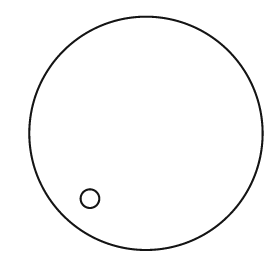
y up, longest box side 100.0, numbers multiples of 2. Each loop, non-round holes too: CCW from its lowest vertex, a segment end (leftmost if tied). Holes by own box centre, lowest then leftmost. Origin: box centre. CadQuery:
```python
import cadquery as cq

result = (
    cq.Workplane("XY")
    .moveTo(0.0, 0.0)
    .circle(50.0)
    .moveTo(-24.0, -28.0)
    .circle(4.0)
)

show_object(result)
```